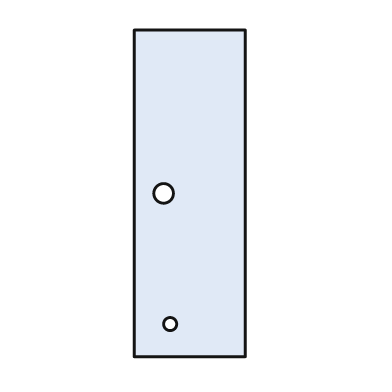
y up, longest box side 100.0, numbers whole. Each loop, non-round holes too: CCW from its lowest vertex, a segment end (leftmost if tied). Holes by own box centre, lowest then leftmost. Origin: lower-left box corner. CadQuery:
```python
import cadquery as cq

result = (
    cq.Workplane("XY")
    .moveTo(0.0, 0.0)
    .lineTo(34.0, 0.0)
    .lineTo(34.0, 100.0)
    .lineTo(0.0, 100.0)
    .close()
    .moveTo(11.0, 10.0)
    .circle(2.0)
    .moveTo(9.0, 50.0)
    .circle(3.0)
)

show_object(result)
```